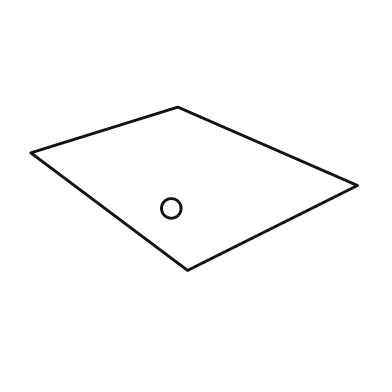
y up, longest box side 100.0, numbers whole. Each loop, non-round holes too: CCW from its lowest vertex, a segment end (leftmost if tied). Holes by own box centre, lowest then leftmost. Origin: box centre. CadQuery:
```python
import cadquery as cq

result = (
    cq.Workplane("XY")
    .moveTo(-2.0, -25.0)
    .lineTo(50.0, 1.0)
    .lineTo(-5.0, 25.0)
    .lineTo(-50.0, 11.0)
    .close()
    .moveTo(-7.0, -6.0)
    .circle(3.0)
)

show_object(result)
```